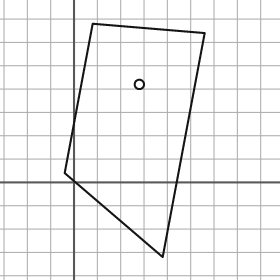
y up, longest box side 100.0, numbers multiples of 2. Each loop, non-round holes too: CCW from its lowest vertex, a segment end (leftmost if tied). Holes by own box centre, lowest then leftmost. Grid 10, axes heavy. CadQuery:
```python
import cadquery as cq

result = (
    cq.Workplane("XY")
    .moveTo(38.0, -32.0)
    .lineTo(56.0, 64.0)
    .lineTo(8.0, 68.0)
    .lineTo(-4.0, 4.0)
    .close()
    .moveTo(28.0, 42.0)
    .circle(2.0)
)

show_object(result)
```